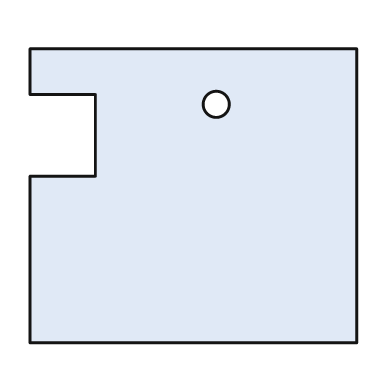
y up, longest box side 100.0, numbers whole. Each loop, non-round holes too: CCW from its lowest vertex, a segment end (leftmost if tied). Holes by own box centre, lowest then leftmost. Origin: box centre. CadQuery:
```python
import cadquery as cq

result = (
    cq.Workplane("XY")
    .moveTo(-50.0, -45.0)
    .lineTo(50.0, -45.0)
    .lineTo(50.0, 45.0)
    .lineTo(-50.0, 45.0)
    .lineTo(-50.0, 31.0)
    .lineTo(-30.0, 31.0)
    .lineTo(-30.0, 6.0)
    .lineTo(-50.0, 6.0)
    .close()
    .moveTo(7.0, 28.0)
    .circle(4.0)
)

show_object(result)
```